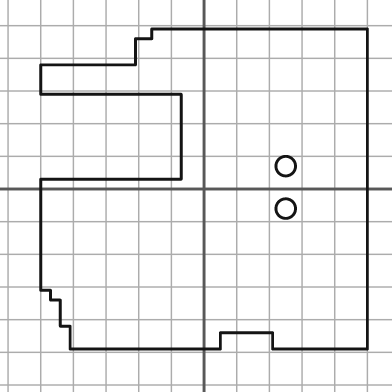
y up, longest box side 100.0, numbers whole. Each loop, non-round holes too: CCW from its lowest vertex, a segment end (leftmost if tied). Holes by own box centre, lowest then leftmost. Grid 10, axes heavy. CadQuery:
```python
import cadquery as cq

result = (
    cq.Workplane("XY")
    .moveTo(-41.0, -49.0)
    .lineTo(5.0, -49.0)
    .lineTo(5.0, -44.0)
    .lineTo(21.0, -44.0)
    .lineTo(21.0, -49.0)
    .lineTo(50.0, -49.0)
    .lineTo(50.0, 49.0)
    .lineTo(-16.0, 49.0)
    .lineTo(-16.0, 46.0)
    .lineTo(-21.0, 46.0)
    .lineTo(-21.0, 38.0)
    .lineTo(-50.0, 38.0)
    .lineTo(-50.0, 29.0)
    .lineTo(-7.0, 29.0)
    .lineTo(-7.0, 3.0)
    .lineTo(-50.0, 3.0)
    .lineTo(-50.0, -31.0)
    .lineTo(-47.0, -31.0)
    .lineTo(-47.0, -34.0)
    .lineTo(-44.0, -34.0)
    .lineTo(-44.0, -42.0)
    .lineTo(-41.0, -42.0)
    .close()
    .moveTo(25.0, -6.0)
    .circle(3.0)
    .moveTo(25.0, 7.0)
    .circle(3.0)
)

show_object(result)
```